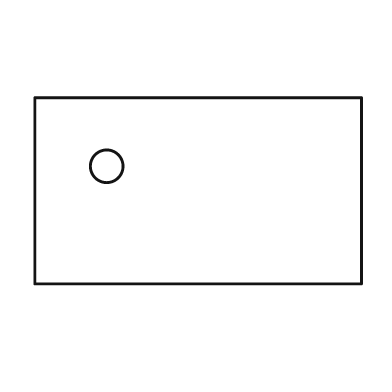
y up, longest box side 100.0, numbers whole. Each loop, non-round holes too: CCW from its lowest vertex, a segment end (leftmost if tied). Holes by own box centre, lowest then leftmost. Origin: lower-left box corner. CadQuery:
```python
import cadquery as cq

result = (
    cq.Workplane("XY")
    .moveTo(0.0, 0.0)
    .lineTo(100.0, 0.0)
    .lineTo(100.0, 57.0)
    .lineTo(0.0, 57.0)
    .close()
    .moveTo(22.0, 36.0)
    .circle(5.0)
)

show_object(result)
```